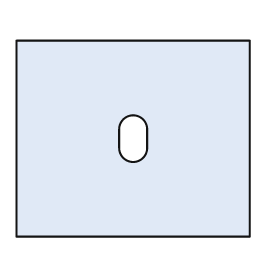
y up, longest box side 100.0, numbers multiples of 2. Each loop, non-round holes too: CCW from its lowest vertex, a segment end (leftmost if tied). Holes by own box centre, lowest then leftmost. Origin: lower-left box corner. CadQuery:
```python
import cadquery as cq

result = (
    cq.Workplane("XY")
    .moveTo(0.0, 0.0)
    .lineTo(100.0, 0.0)
    .lineTo(100.0, 84.0)
    .lineTo(0.0, 84.0)
    .close()
    .moveTo(44.0, 38.0)
    .threePointArc((50.0, 32.0), (56.0, 38.0))
    .lineTo(56.0, 46.0)
    .threePointArc((50.0, 52.0), (44.0, 46.0))
    .close()
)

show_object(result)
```